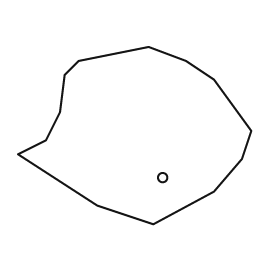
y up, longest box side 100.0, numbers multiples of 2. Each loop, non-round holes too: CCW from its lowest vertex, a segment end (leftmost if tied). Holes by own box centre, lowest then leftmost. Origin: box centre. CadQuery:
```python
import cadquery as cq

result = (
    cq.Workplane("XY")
    .moveTo(8.0, -38.0)
    .lineTo(34.0, -24.0)
    .lineTo(46.0, -10.0)
    .lineTo(50.0, 2.0)
    .lineTo(34.0, 24.0)
    .lineTo(22.0, 32.0)
    .lineTo(6.0, 38.0)
    .lineTo(-24.0, 32.0)
    .lineTo(-30.0, 26.0)
    .lineTo(-32.0, 10.0)
    .lineTo(-38.0, -2.0)
    .lineTo(-50.0, -8.0)
    .lineTo(-16.0, -30.0)
    .close()
    .moveTo(12.0, -18.0)
    .circle(2.0)
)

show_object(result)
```